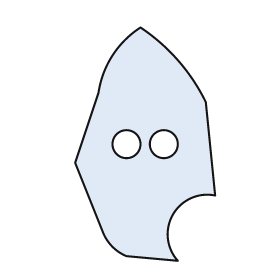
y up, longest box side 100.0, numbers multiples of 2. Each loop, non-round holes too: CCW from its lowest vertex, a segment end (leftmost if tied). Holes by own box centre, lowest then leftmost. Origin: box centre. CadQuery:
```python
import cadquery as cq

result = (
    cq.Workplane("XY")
    .moveTo(14.0, -50.0)
    .threePointArc((12.0, -30.0), (30.0, -22.0))
    .lineTo(26.0, 18.0)
    .threePointArc((14.0, 36.0), (-2.0, 50.0))
    .threePointArc((-14.0, 38.0), (-20.0, 22.0))
    .lineTo(-30.0, -8.0)
    .lineTo(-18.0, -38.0)
    .threePointArc((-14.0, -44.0), (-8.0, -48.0))
    .close()
    .moveTo(-8.0, 0.0)
    .circle(6.0)
    .moveTo(8.0, 0.0)
    .circle(6.0)
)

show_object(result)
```